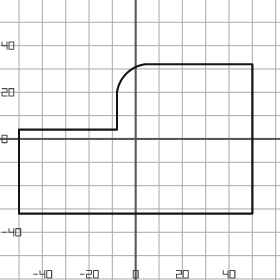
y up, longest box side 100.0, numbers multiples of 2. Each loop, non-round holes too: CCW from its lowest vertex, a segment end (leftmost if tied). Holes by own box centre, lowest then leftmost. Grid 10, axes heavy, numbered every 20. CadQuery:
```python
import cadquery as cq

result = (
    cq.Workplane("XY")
    .moveTo(-50.0, -32.0)
    .lineTo(50.0, -32.0)
    .lineTo(50.0, 32.0)
    .lineTo(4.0, 32.0)
    .threePointArc((-4.0, 28.0), (-8.0, 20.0))
    .lineTo(-8.0, 4.0)
    .lineTo(-50.0, 4.0)
    .close()
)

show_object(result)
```